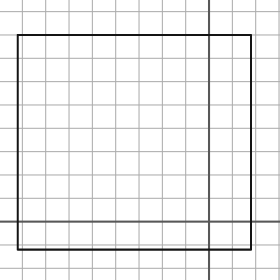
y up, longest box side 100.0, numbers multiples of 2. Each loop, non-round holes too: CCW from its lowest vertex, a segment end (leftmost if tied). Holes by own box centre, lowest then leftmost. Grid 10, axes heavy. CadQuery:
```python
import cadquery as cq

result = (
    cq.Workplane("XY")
    .moveTo(-82.0, -12.0)
    .lineTo(18.0, -12.0)
    .lineTo(18.0, 80.0)
    .lineTo(-82.0, 80.0)
    .close()
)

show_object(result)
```